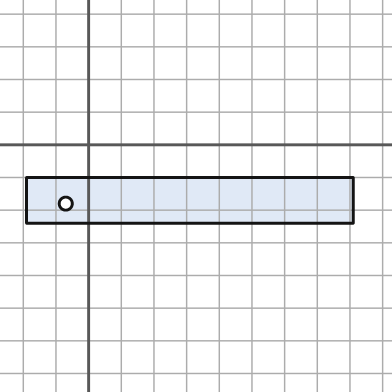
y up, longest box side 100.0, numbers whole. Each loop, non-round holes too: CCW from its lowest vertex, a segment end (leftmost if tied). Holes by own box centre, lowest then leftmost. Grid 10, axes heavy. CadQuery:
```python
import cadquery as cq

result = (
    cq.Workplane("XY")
    .moveTo(-19.0, -24.0)
    .lineTo(81.0, -24.0)
    .lineTo(81.0, -10.0)
    .lineTo(-19.0, -10.0)
    .close()
    .moveTo(-7.0, -18.0)
    .circle(2.0)
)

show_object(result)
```